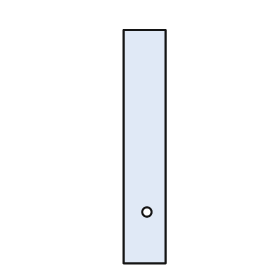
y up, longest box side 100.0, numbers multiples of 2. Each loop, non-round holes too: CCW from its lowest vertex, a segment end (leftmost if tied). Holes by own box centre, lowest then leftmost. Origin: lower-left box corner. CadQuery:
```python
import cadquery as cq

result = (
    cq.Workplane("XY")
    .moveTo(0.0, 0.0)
    .lineTo(18.0, 0.0)
    .lineTo(18.0, 100.0)
    .lineTo(0.0, 100.0)
    .close()
    .moveTo(10.0, 22.0)
    .circle(2.0)
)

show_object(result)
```